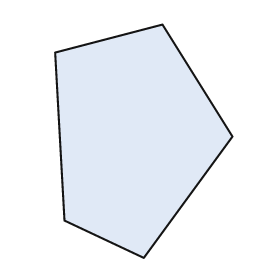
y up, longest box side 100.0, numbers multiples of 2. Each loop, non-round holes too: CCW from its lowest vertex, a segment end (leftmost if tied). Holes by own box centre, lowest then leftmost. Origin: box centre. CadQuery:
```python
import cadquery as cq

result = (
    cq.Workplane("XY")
    .moveTo(0.0, -50.0)
    .lineTo(38.0, 2.0)
    .lineTo(8.0, 50.0)
    .lineTo(-38.0, 38.0)
    .lineTo(-34.0, -34.0)
    .close()
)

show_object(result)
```